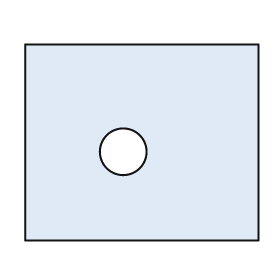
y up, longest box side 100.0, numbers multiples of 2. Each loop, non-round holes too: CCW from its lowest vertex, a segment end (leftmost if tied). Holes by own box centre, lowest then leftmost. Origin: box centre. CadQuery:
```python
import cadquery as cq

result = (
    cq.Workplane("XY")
    .moveTo(-50.0, -42.0)
    .lineTo(50.0, -42.0)
    .lineTo(50.0, 42.0)
    .lineTo(-50.0, 42.0)
    .close()
    .moveTo(-8.0, -4.0)
    .circle(10.0)
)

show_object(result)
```